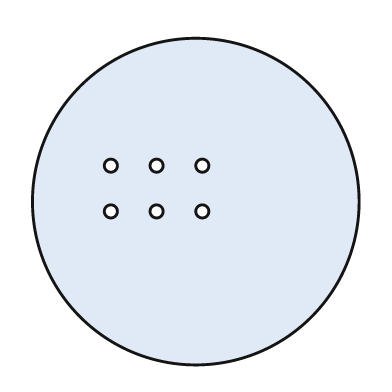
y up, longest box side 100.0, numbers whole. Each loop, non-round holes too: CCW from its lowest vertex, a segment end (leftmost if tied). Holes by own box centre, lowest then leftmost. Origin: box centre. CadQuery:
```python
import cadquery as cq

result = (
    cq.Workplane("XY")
    .moveTo(0.0, 0.0)
    .circle(50.0)
    .moveTo(-26.0, -3.0)
    .circle(2.0)
    .moveTo(-12.0, -3.0)
    .circle(2.0)
    .moveTo(2.0, -3.0)
    .circle(2.0)
    .moveTo(-26.0, 11.0)
    .circle(2.0)
    .moveTo(-12.0, 11.0)
    .circle(2.0)
    .moveTo(2.0, 11.0)
    .circle(2.0)
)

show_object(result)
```